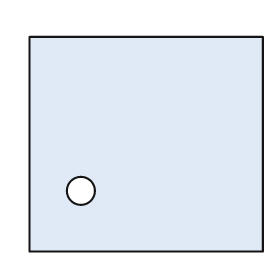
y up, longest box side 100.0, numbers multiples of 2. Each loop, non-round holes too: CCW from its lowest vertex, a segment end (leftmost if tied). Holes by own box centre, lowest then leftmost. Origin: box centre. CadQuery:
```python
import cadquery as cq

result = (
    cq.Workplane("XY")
    .moveTo(-50.0, -46.0)
    .lineTo(50.0, -46.0)
    .lineTo(50.0, 46.0)
    .lineTo(-50.0, 46.0)
    .close()
    .moveTo(-28.0, -20.0)
    .circle(6.0)
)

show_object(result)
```